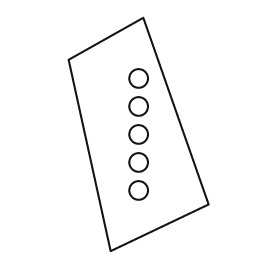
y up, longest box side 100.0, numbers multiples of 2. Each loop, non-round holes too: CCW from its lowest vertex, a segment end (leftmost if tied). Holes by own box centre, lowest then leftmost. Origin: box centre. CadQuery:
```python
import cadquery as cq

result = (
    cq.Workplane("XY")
    .moveTo(-12.0, -50.0)
    .lineTo(30.0, -30.0)
    .lineTo(2.0, 50.0)
    .lineTo(-30.0, 32.0)
    .close()
    .moveTo(0.0, -24.0)
    .circle(4.0)
    .moveTo(0.0, -12.0)
    .circle(4.0)
    .moveTo(0.0, 0.0)
    .circle(4.0)
    .moveTo(0.0, 12.0)
    .circle(4.0)
    .moveTo(0.0, 24.0)
    .circle(4.0)
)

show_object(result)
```